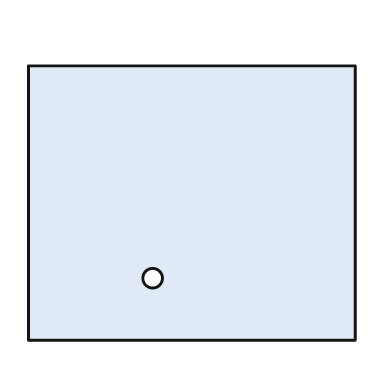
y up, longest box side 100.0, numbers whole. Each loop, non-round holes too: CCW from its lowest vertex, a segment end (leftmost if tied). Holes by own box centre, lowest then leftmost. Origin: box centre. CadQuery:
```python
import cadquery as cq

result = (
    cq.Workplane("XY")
    .moveTo(-50.0, -42.0)
    .lineTo(50.0, -42.0)
    .lineTo(50.0, 42.0)
    .lineTo(-50.0, 42.0)
    .close()
    .moveTo(-12.0, -23.0)
    .circle(3.0)
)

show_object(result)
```